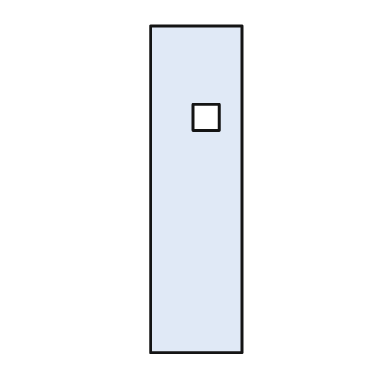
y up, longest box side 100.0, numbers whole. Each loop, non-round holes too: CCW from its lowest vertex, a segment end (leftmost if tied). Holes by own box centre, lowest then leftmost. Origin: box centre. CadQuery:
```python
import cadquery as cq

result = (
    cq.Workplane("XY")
    .moveTo(-14.0, -50.0)
    .lineTo(14.0, -50.0)
    .lineTo(14.0, 50.0)
    .lineTo(-14.0, 50.0)
    .close()
    .moveTo(-1.0, 18.0)
    .lineTo(7.0, 18.0)
    .lineTo(7.0, 26.0)
    .lineTo(-1.0, 26.0)
    .close()
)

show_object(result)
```